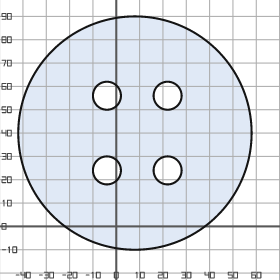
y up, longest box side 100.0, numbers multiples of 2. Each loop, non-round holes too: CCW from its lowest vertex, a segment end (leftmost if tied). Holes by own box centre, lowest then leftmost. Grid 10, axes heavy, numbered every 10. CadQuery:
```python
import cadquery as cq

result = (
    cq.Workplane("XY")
    .moveTo(8.0, 40.0)
    .circle(50.0)
    .moveTo(-4.0, 24.0)
    .circle(6.0)
    .moveTo(22.0, 24.0)
    .circle(6.0)
    .moveTo(-4.0, 56.0)
    .circle(6.0)
    .moveTo(22.0, 56.0)
    .circle(6.0)
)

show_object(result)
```